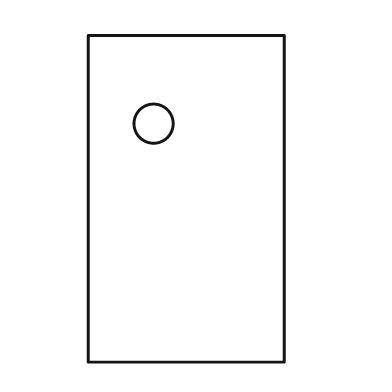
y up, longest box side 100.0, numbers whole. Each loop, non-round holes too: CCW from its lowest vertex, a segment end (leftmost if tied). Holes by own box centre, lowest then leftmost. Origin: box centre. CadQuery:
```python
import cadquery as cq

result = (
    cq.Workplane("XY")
    .moveTo(-30.0, -50.0)
    .lineTo(30.0, -50.0)
    .lineTo(30.0, 50.0)
    .lineTo(-30.0, 50.0)
    .close()
    .moveTo(-10.0, 23.0)
    .circle(6.0)
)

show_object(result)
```